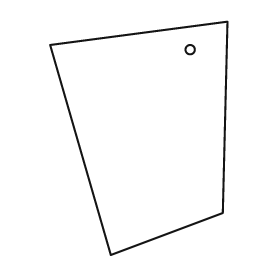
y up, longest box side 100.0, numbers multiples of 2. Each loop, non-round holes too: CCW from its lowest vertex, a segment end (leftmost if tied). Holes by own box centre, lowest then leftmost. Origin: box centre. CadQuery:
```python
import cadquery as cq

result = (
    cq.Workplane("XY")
    .moveTo(-12.0, -50.0)
    .lineTo(36.0, -32.0)
    .lineTo(38.0, 50.0)
    .lineTo(-38.0, 40.0)
    .close()
    .moveTo(22.0, 38.0)
    .circle(2.0)
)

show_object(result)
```